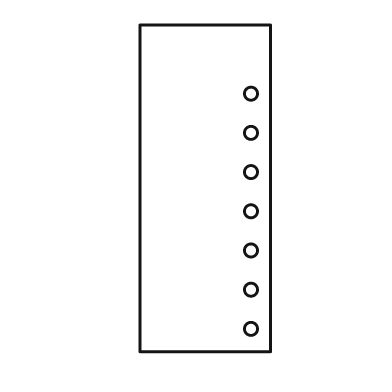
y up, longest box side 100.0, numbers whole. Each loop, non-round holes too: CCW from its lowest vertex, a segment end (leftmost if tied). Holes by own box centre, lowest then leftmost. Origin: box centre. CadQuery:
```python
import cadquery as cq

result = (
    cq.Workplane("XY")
    .moveTo(-20.0, -50.0)
    .lineTo(20.0, -50.0)
    .lineTo(20.0, 50.0)
    .lineTo(-20.0, 50.0)
    .close()
    .moveTo(14.0, -43.0)
    .circle(2.0)
    .moveTo(14.0, -31.0)
    .circle(2.0)
    .moveTo(14.0, -19.0)
    .circle(2.0)
    .moveTo(14.0, -7.0)
    .circle(2.0)
    .moveTo(14.0, 5.0)
    .circle(2.0)
    .moveTo(14.0, 17.0)
    .circle(2.0)
    .moveTo(14.0, 29.0)
    .circle(2.0)
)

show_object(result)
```